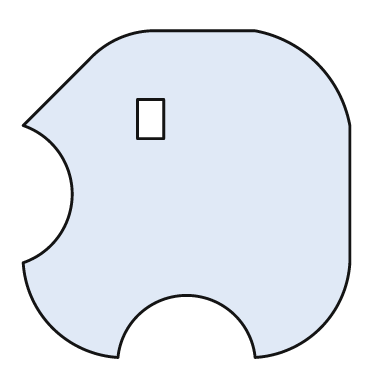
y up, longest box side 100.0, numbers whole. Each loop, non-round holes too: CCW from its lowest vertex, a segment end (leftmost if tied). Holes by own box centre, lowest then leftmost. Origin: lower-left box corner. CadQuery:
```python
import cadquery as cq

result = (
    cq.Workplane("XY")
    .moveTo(29.0, 0.0)
    .threePointArc((50.0, 19.0), (71.0, 0.0))
    .threePointArc((91.0, 9.0), (100.0, 29.0))
    .lineTo(100.0, 71.0)
    .threePointArc((90.0, 90.0), (71.0, 100.0))
    .lineTo(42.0, 100.0)
    .threePointArc((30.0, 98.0), (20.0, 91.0))
    .lineTo(0.0, 71.0)
    .threePointArc((15.0, 50.0), (0.0, 29.0))
    .threePointArc((9.0, 9.0), (29.0, 0.0))
    .close()
    .moveTo(35.0, 67.0)
    .lineTo(43.0, 67.0)
    .lineTo(43.0, 79.0)
    .lineTo(35.0, 79.0)
    .close()
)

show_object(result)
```